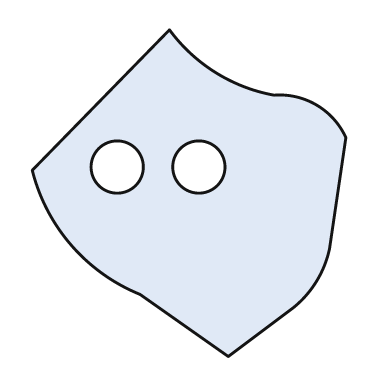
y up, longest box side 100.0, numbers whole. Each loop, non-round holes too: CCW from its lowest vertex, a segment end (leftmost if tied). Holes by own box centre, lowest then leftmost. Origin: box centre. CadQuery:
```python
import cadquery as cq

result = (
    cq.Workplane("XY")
    .moveTo(12.0, -50.0)
    .lineTo(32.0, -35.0)
    .threePointArc((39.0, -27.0), (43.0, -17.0))
    .lineTo(48.0, 17.0)
    .threePointArc((39.0, 27.0), (26.0, 30.0))
    .threePointArc((8.0, 37.0), (-6.0, 50.0))
    .lineTo(-48.0, 7.0)
    .threePointArc((-36.0, -16.0), (-15.0, -31.0))
    .close()
    .moveTo(-22.0, 8.0)
    .circle(8.0)
    .moveTo(3.0, 8.0)
    .circle(8.0)
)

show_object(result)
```